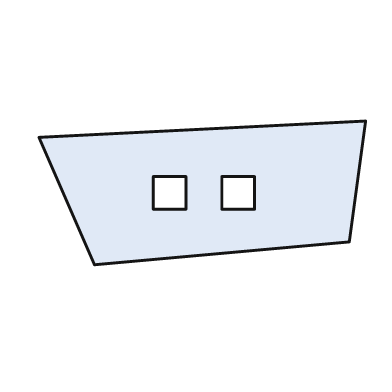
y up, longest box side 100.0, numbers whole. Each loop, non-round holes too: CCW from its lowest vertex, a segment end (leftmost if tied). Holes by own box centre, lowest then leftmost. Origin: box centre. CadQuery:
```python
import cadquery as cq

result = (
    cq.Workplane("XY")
    .moveTo(-33.0, -22.0)
    .lineTo(45.0, -15.0)
    .lineTo(50.0, 22.0)
    .lineTo(-50.0, 17.0)
    .close()
    .moveTo(-15.0, -5.0)
    .lineTo(-5.0, -5.0)
    .lineTo(-5.0, 5.0)
    .lineTo(-15.0, 5.0)
    .close()
    .moveTo(6.0, -5.0)
    .lineTo(16.0, -5.0)
    .lineTo(16.0, 5.0)
    .lineTo(6.0, 5.0)
    .close()
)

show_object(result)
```